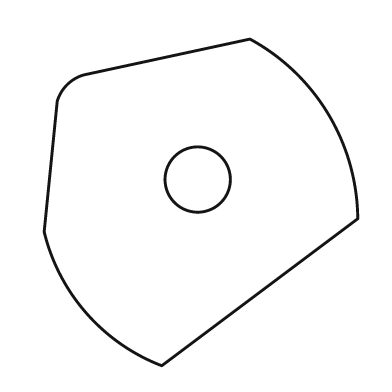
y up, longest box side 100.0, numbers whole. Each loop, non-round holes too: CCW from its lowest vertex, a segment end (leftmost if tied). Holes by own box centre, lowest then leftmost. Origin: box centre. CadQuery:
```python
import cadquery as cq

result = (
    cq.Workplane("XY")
    .moveTo(-12.0, -50.0)
    .lineTo(48.0, -5.0)
    .threePointArc((39.0, 27.0), (15.0, 50.0))
    .lineTo(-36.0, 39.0)
    .threePointArc((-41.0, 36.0), (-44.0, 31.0))
    .lineTo(-48.0, -9.0)
    .threePointArc((-35.0, -34.0), (-12.0, -50.0))
    .close()
    .moveTo(-1.0, 7.0)
    .circle(10.0)
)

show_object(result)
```